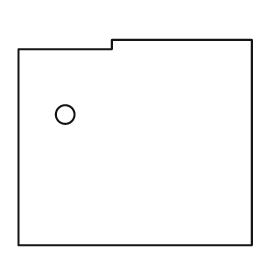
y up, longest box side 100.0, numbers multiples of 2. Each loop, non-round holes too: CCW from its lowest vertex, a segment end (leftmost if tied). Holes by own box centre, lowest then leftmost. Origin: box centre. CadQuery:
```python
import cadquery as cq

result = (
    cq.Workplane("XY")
    .moveTo(-50.0, -44.0)
    .lineTo(50.0, -44.0)
    .lineTo(50.0, 44.0)
    .lineTo(-10.0, 44.0)
    .lineTo(-10.0, 40.0)
    .lineTo(-50.0, 40.0)
    .close()
    .moveTo(-30.0, 12.0)
    .circle(4.0)
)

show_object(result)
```